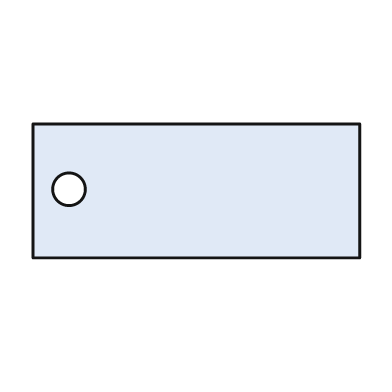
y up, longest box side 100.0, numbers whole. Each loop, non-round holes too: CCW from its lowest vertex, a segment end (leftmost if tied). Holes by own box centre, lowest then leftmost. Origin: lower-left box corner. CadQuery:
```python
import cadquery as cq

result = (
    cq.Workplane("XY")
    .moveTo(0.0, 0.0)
    .lineTo(100.0, 0.0)
    .lineTo(100.0, 41.0)
    .lineTo(0.0, 41.0)
    .close()
    .moveTo(11.0, 21.0)
    .circle(5.0)
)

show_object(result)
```